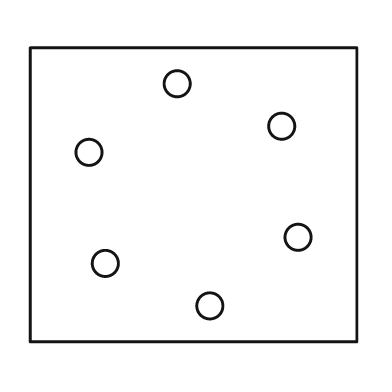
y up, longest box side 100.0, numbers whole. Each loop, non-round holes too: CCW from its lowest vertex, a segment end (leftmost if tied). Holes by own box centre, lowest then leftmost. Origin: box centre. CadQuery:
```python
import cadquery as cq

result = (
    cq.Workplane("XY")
    .moveTo(-50.0, -45.0)
    .lineTo(50.0, -45.0)
    .lineTo(50.0, 45.0)
    .lineTo(-50.0, 45.0)
    .close()
    .moveTo(5.0, -34.0)
    .circle(4.0)
    .moveTo(-27.0, -21.0)
    .circle(4.0)
    .moveTo(32.0, -13.0)
    .circle(4.0)
    .moveTo(-32.0, 13.0)
    .circle(4.0)
    .moveTo(27.0, 21.0)
    .circle(4.0)
    .moveTo(-5.0, 34.0)
    .circle(4.0)
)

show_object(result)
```